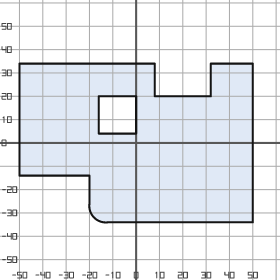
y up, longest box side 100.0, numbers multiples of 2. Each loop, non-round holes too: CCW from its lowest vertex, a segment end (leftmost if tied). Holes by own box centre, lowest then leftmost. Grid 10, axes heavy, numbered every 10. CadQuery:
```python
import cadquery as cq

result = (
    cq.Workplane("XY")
    .moveTo(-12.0, -34.0)
    .lineTo(50.0, -34.0)
    .lineTo(50.0, 34.0)
    .lineTo(32.0, 34.0)
    .lineTo(32.0, 20.0)
    .lineTo(8.0, 20.0)
    .lineTo(8.0, 34.0)
    .lineTo(-50.0, 34.0)
    .lineTo(-50.0, -14.0)
    .lineTo(-20.0, -14.0)
    .lineTo(-20.0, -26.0)
    .threePointArc((-18.0, -32.0), (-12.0, -34.0))
    .close()
    .moveTo(-16.0, 4.0)
    .lineTo(0.0, 4.0)
    .lineTo(0.0, 20.0)
    .lineTo(-16.0, 20.0)
    .close()
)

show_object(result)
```